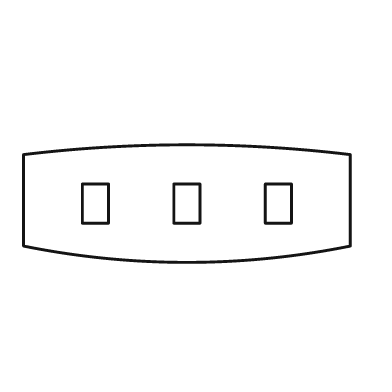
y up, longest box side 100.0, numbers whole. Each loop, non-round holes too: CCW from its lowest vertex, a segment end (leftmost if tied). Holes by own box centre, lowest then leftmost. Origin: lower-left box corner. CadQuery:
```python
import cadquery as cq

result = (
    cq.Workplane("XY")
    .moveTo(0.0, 5.0)
    .threePointArc((50.0, 0.0), (100.0, 5.0))
    .lineTo(100.0, 33.0)
    .threePointArc((50.0, 36.0), (0.0, 33.0))
    .close()
    .moveTo(18.0, 12.0)
    .lineTo(26.0, 12.0)
    .lineTo(26.0, 24.0)
    .lineTo(18.0, 24.0)
    .close()
    .moveTo(46.0, 12.0)
    .lineTo(54.0, 12.0)
    .lineTo(54.0, 24.0)
    .lineTo(46.0, 24.0)
    .close()
    .moveTo(74.0, 12.0)
    .lineTo(82.0, 12.0)
    .lineTo(82.0, 24.0)
    .lineTo(74.0, 24.0)
    .close()
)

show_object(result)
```